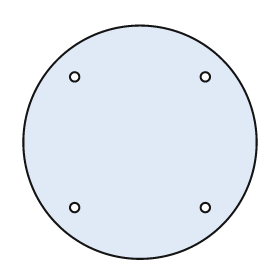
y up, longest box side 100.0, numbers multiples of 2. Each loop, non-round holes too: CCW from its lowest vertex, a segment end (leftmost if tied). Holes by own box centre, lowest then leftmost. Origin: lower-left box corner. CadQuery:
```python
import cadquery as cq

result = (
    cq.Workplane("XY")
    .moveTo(50.0, 50.0)
    .circle(50.0)
    .moveTo(22.0, 22.0)
    .circle(2.0)
    .moveTo(78.0, 22.0)
    .circle(2.0)
    .moveTo(22.0, 78.0)
    .circle(2.0)
    .moveTo(78.0, 78.0)
    .circle(2.0)
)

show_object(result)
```